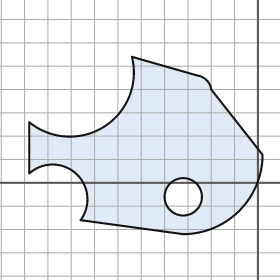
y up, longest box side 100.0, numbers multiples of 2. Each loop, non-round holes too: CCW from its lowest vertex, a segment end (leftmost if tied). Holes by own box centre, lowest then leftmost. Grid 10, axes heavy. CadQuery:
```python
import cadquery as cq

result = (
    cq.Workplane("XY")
    .moveTo(-32.0, -22.0)
    .threePointArc((-8.0, -12.0), (2.0, 12.0))
    .lineTo(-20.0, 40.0)
    .threePointArc((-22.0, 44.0), (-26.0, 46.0))
    .lineTo(-54.0, 54.0)
    .threePointArc((-66.0, 24.0), (-98.0, 26.0))
    .lineTo(-98.0, 4.0)
    .threePointArc((-78.0, 4.0), (-76.0, -16.0))
    .close()
    .moveTo(-32.0, -6.0)
    .circle(8.0)
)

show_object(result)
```